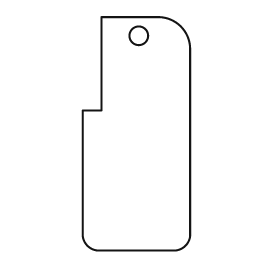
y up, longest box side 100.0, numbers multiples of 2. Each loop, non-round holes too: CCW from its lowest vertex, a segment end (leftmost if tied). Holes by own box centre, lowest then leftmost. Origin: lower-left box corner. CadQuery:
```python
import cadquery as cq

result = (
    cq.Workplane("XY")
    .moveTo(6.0, 0.0)
    .lineTo(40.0, 0.0)
    .threePointArc((44.0, 2.0), (46.0, 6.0))
    .lineTo(46.0, 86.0)
    .threePointArc((42.0, 96.0), (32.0, 100.0))
    .lineTo(8.0, 100.0)
    .lineTo(8.0, 60.0)
    .lineTo(0.0, 60.0)
    .lineTo(0.0, 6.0)
    .threePointArc((2.0, 2.0), (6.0, 0.0))
    .close()
    .moveTo(24.0, 92.0)
    .circle(4.0)
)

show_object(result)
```